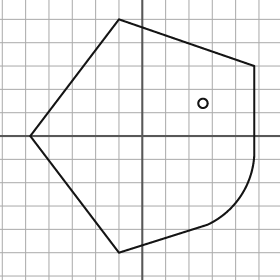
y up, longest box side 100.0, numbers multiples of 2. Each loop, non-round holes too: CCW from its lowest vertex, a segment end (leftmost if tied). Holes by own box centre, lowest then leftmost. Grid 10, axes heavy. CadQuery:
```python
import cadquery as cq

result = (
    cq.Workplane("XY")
    .moveTo(-10.0, -50.0)
    .lineTo(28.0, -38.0)
    .threePointArc((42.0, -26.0), (48.0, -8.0))
    .lineTo(48.0, 30.0)
    .lineTo(-10.0, 50.0)
    .lineTo(-48.0, 0.0)
    .close()
    .moveTo(26.0, 14.0)
    .circle(2.0)
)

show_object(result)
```